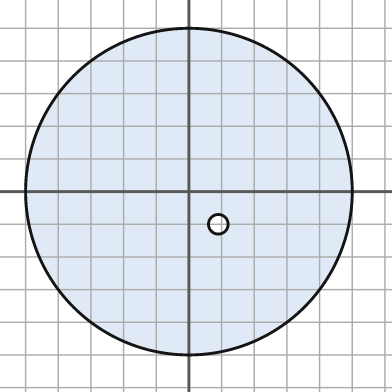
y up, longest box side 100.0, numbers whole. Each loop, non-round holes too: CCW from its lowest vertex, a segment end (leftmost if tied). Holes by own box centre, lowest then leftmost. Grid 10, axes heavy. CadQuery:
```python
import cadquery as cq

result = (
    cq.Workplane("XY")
    .moveTo(0.0, 0.0)
    .circle(50.0)
    .moveTo(9.0, -10.0)
    .circle(3.0)
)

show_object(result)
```